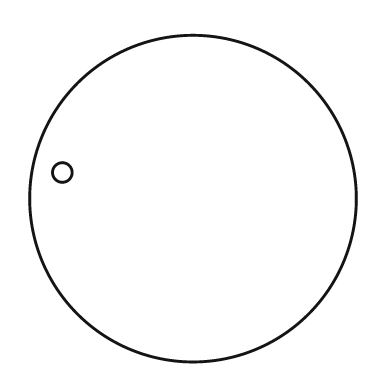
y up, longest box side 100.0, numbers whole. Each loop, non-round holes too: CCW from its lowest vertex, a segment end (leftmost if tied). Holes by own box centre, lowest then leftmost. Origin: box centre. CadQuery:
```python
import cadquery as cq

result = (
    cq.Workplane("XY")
    .moveTo(0.0, 0.0)
    .circle(50.0)
    .moveTo(-40.0, 8.0)
    .circle(3.0)
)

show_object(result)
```